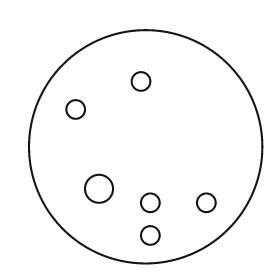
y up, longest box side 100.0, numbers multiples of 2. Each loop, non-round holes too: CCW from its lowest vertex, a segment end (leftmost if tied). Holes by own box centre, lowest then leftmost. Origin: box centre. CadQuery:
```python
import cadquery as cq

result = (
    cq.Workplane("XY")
    .moveTo(0.0, 0.0)
    .circle(50.0)
    .moveTo(2.0, -38.0)
    .circle(4.0)
    .moveTo(2.0, -24.0)
    .circle(4.0)
    .moveTo(26.0, -24.0)
    .circle(4.0)
    .moveTo(-20.0, -18.0)
    .circle(6.0)
    .moveTo(-30.0, 16.0)
    .circle(4.0)
    .moveTo(-2.0, 28.0)
    .circle(4.0)
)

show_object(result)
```